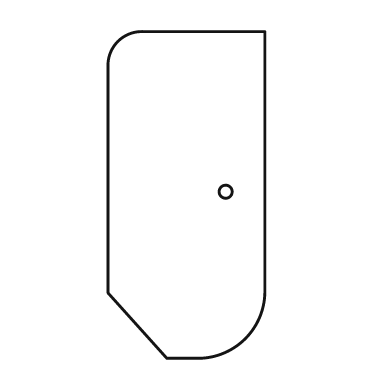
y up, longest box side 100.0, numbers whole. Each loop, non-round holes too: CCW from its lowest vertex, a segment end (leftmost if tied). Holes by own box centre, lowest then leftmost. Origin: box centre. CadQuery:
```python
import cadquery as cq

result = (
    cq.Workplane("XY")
    .moveTo(-6.0, -50.0)
    .lineTo(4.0, -50.0)
    .threePointArc((18.0, -44.0), (24.0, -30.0))
    .lineTo(24.0, 50.0)
    .lineTo(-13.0, 50.0)
    .threePointArc((-21.0, 47.0), (-24.0, 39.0))
    .lineTo(-24.0, -30.0)
    .close()
    .moveTo(12.0, 1.0)
    .circle(2.0)
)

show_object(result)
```